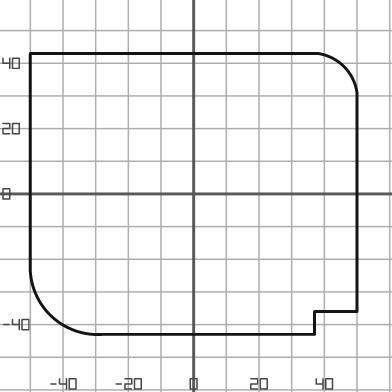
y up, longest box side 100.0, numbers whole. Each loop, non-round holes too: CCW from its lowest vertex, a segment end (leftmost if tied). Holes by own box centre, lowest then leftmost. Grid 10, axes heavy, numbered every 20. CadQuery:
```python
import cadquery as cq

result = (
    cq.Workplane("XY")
    .moveTo(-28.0, -43.0)
    .lineTo(37.0, -43.0)
    .lineTo(37.0, -36.0)
    .lineTo(50.0, -36.0)
    .lineTo(50.0, 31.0)
    .threePointArc((46.0, 39.0), (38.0, 43.0))
    .lineTo(-50.0, 43.0)
    .lineTo(-50.0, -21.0)
    .threePointArc((-44.0, -37.0), (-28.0, -43.0))
    .close()
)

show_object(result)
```